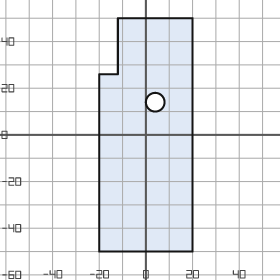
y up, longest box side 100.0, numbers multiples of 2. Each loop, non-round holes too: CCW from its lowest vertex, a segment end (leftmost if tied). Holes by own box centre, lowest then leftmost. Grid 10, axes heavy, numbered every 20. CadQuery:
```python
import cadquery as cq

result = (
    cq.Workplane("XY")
    .moveTo(-20.0, -50.0)
    .lineTo(20.0, -50.0)
    .lineTo(20.0, 50.0)
    .lineTo(-12.0, 50.0)
    .lineTo(-12.0, 26.0)
    .lineTo(-20.0, 26.0)
    .close()
    .moveTo(4.0, 14.0)
    .circle(4.0)
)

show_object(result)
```